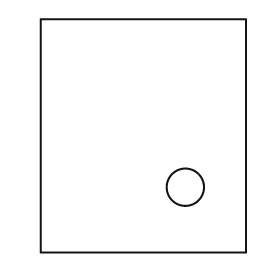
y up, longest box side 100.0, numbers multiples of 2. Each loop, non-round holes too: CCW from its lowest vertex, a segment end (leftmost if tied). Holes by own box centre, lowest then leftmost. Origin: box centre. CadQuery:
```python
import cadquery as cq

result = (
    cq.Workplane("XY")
    .moveTo(-44.0, -50.0)
    .lineTo(44.0, -50.0)
    .lineTo(44.0, 50.0)
    .lineTo(-44.0, 50.0)
    .close()
    .moveTo(18.0, -22.0)
    .circle(8.0)
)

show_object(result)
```